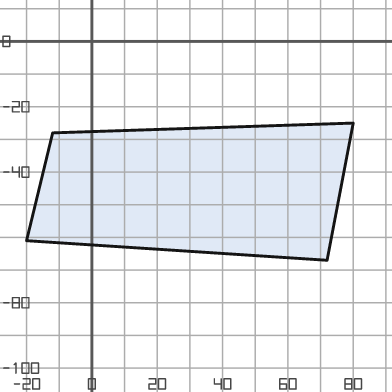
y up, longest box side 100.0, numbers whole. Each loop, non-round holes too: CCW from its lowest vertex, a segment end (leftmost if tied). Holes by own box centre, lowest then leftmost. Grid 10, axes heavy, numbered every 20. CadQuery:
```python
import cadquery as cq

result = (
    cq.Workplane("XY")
    .moveTo(72.0, -67.0)
    .lineTo(80.0, -25.0)
    .lineTo(-12.0, -28.0)
    .lineTo(-20.0, -61.0)
    .close()
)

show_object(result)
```